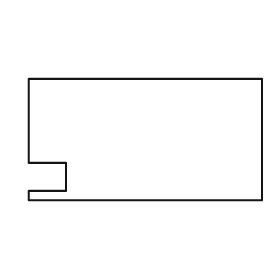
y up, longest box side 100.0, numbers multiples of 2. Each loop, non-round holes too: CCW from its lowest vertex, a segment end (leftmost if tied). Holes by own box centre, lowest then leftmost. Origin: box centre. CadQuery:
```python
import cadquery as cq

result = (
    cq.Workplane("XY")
    .moveTo(-50.0, -26.0)
    .lineTo(50.0, -26.0)
    .lineTo(50.0, 26.0)
    .lineTo(-50.0, 26.0)
    .lineTo(-50.0, -10.0)
    .lineTo(-34.0, -10.0)
    .lineTo(-34.0, -22.0)
    .lineTo(-50.0, -22.0)
    .close()
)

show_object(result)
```